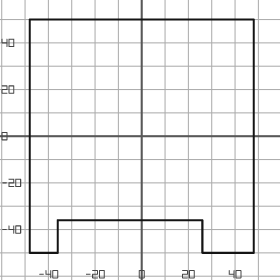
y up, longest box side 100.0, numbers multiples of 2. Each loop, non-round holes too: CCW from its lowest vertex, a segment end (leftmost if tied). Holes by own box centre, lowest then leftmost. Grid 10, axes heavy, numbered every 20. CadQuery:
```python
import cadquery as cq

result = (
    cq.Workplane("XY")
    .moveTo(-48.0, -50.0)
    .lineTo(-36.0, -50.0)
    .lineTo(-36.0, -36.0)
    .lineTo(26.0, -36.0)
    .lineTo(26.0, -50.0)
    .lineTo(48.0, -50.0)
    .lineTo(48.0, 50.0)
    .lineTo(-48.0, 50.0)
    .close()
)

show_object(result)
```